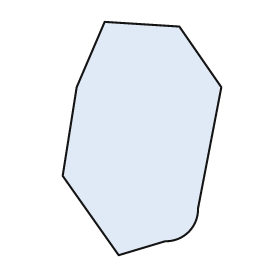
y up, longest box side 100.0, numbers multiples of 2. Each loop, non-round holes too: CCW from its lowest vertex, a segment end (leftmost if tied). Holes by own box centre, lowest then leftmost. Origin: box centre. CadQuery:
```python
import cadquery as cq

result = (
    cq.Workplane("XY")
    .moveTo(-10.0, -50.0)
    .lineTo(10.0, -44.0)
    .threePointArc((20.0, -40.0), (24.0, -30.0))
    .lineTo(34.0, 22.0)
    .lineTo(16.0, 48.0)
    .lineTo(-16.0, 50.0)
    .lineTo(-28.0, 22.0)
    .lineTo(-34.0, -16.0)
    .close()
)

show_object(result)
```